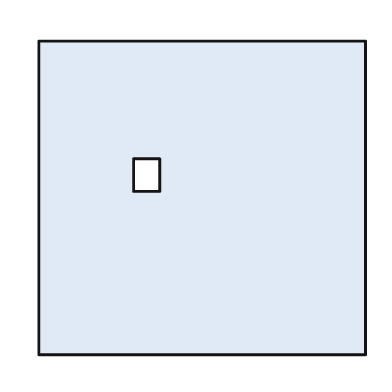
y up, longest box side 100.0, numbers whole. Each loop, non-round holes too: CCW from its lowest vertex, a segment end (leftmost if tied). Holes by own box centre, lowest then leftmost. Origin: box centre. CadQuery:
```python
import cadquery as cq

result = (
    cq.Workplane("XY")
    .moveTo(-50.0, -48.0)
    .lineTo(50.0, -48.0)
    .lineTo(50.0, 48.0)
    .lineTo(-50.0, 48.0)
    .close()
    .moveTo(-21.0, 2.0)
    .lineTo(-13.0, 2.0)
    .lineTo(-13.0, 12.0)
    .lineTo(-21.0, 12.0)
    .close()
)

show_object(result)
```